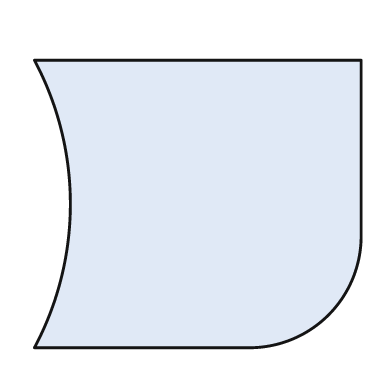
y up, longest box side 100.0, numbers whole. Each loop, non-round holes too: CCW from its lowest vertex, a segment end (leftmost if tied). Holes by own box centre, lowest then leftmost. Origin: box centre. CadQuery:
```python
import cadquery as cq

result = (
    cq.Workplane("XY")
    .moveTo(-50.0, -44.0)
    .lineTo(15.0, -44.0)
    .threePointArc((40.0, -34.0), (50.0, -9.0))
    .lineTo(50.0, 44.0)
    .lineTo(-50.0, 44.0)
    .threePointArc((-39.0, 0.0), (-50.0, -44.0))
    .close()
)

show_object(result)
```